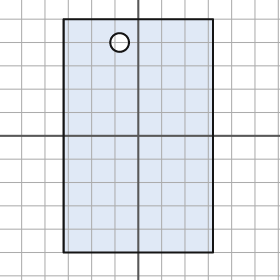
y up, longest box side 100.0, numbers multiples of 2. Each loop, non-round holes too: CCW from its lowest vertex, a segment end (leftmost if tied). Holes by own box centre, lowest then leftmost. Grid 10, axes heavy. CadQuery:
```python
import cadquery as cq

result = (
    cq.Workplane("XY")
    .moveTo(-32.0, -50.0)
    .lineTo(32.0, -50.0)
    .lineTo(32.0, 50.0)
    .lineTo(-32.0, 50.0)
    .close()
    .moveTo(-8.0, 40.0)
    .circle(4.0)
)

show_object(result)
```